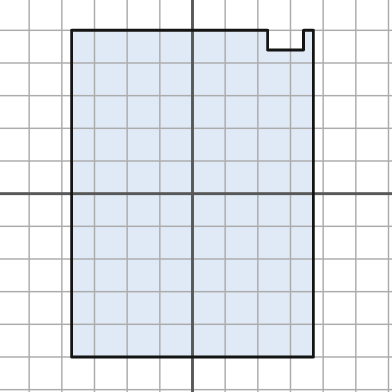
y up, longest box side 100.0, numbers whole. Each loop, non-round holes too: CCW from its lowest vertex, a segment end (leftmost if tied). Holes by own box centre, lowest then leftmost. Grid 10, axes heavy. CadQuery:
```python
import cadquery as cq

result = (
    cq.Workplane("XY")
    .moveTo(-37.0, -50.0)
    .lineTo(37.0, -50.0)
    .lineTo(37.0, 50.0)
    .lineTo(34.0, 50.0)
    .lineTo(34.0, 44.0)
    .lineTo(23.0, 44.0)
    .lineTo(23.0, 50.0)
    .lineTo(-37.0, 50.0)
    .close()
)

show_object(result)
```